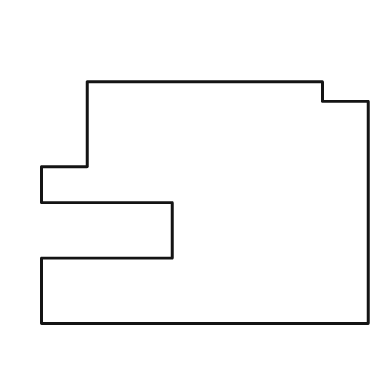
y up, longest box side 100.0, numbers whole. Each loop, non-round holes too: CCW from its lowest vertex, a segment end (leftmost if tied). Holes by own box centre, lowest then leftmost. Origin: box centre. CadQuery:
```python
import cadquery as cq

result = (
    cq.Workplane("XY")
    .moveTo(-50.0, -37.0)
    .lineTo(50.0, -37.0)
    .lineTo(50.0, 31.0)
    .lineTo(36.0, 31.0)
    .lineTo(36.0, 37.0)
    .lineTo(-36.0, 37.0)
    .lineTo(-36.0, 11.0)
    .lineTo(-50.0, 11.0)
    .lineTo(-50.0, 0.0)
    .lineTo(-10.0, 0.0)
    .lineTo(-10.0, -17.0)
    .lineTo(-50.0, -17.0)
    .close()
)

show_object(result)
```